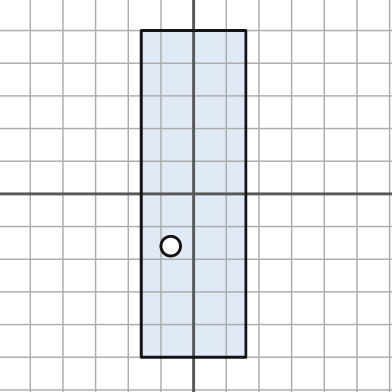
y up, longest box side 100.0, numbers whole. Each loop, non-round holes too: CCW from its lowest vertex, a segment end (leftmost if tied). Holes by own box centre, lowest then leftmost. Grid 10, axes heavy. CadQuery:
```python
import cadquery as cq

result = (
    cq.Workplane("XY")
    .moveTo(-16.0, -50.0)
    .lineTo(16.0, -50.0)
    .lineTo(16.0, 50.0)
    .lineTo(-16.0, 50.0)
    .close()
    .moveTo(-7.0, -16.0)
    .circle(3.0)
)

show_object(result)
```